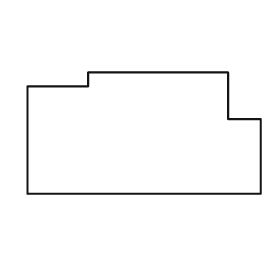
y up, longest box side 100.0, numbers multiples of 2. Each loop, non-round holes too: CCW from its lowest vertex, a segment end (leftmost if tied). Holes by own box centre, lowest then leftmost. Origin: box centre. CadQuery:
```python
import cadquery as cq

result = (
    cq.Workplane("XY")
    .moveTo(-50.0, -26.0)
    .lineTo(50.0, -26.0)
    .lineTo(50.0, 6.0)
    .lineTo(36.0, 6.0)
    .lineTo(36.0, 26.0)
    .lineTo(-24.0, 26.0)
    .lineTo(-24.0, 20.0)
    .lineTo(-50.0, 20.0)
    .close()
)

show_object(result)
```